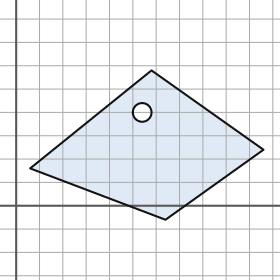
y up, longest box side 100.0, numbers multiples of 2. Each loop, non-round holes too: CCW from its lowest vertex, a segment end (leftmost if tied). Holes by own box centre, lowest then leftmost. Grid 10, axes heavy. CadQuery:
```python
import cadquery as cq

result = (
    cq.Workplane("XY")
    .moveTo(64.0, -6.0)
    .lineTo(106.0, 24.0)
    .lineTo(58.0, 58.0)
    .lineTo(6.0, 16.0)
    .close()
    .moveTo(54.0, 40.0)
    .circle(4.0)
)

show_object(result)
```